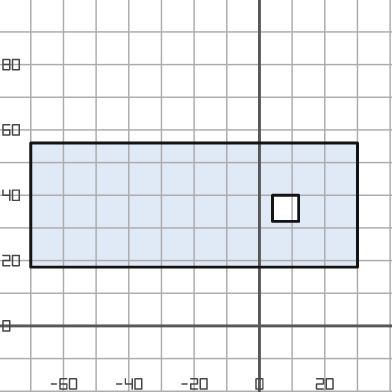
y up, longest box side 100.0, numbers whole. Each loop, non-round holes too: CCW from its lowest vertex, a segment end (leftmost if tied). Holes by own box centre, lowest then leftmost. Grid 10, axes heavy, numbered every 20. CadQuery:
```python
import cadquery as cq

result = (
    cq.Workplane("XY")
    .moveTo(-70.0, 18.0)
    .lineTo(30.0, 18.0)
    .lineTo(30.0, 56.0)
    .lineTo(-70.0, 56.0)
    .close()
    .moveTo(4.0, 32.0)
    .lineTo(12.0, 32.0)
    .lineTo(12.0, 40.0)
    .lineTo(4.0, 40.0)
    .close()
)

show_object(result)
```